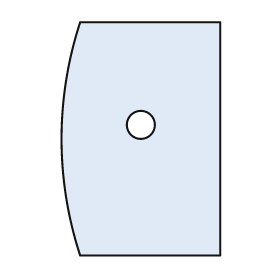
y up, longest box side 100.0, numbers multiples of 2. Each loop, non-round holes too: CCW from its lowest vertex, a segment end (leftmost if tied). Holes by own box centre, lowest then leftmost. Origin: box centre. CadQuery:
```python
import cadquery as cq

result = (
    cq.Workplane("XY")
    .moveTo(-26.0, -50.0)
    .lineTo(34.0, -50.0)
    .lineTo(34.0, 50.0)
    .lineTo(-26.0, 50.0)
    .threePointArc((-34.0, 0.0), (-26.0, -50.0))
    .close()
    .moveTo(0.0, 6.0)
    .circle(6.0)
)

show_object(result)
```